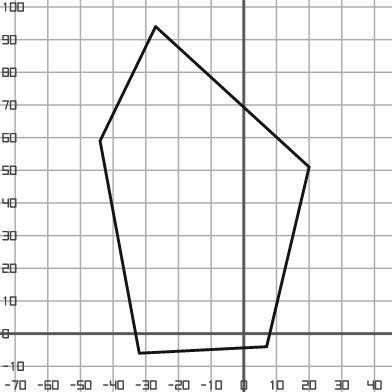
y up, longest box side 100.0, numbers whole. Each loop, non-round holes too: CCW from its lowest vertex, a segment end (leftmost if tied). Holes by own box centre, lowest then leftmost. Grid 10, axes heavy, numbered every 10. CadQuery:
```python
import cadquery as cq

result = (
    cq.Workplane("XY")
    .moveTo(-32.0, -6.0)
    .lineTo(7.0, -4.0)
    .lineTo(20.0, 51.0)
    .lineTo(-27.0, 94.0)
    .lineTo(-44.0, 59.0)
    .close()
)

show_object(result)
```